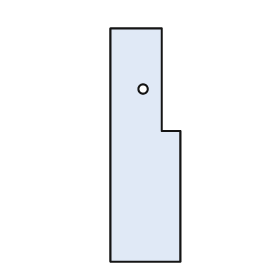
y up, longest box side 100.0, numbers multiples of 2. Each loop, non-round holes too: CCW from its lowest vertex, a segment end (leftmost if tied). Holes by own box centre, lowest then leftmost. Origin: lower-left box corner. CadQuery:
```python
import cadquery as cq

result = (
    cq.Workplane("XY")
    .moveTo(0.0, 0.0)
    .lineTo(30.0, 0.0)
    .lineTo(30.0, 56.0)
    .lineTo(22.0, 56.0)
    .lineTo(22.0, 100.0)
    .lineTo(0.0, 100.0)
    .close()
    .moveTo(14.0, 74.0)
    .circle(2.0)
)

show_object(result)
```